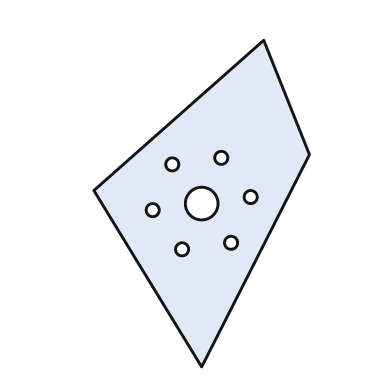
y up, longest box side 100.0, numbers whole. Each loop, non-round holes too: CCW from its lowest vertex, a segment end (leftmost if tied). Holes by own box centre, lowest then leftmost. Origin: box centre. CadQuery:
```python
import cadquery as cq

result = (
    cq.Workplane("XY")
    .moveTo(0.0, -50.0)
    .lineTo(33.0, 15.0)
    .lineTo(19.0, 50.0)
    .lineTo(-33.0, 4.0)
    .close()
    .moveTo(-6.0, -14.0)
    .circle(2.0)
    .moveTo(9.0, -12.0)
    .circle(2.0)
    .moveTo(-15.0, -2.0)
    .circle(2.0)
    .moveTo(0.0, 0.0)
    .circle(5.0)
    .moveTo(15.0, 2.0)
    .circle(2.0)
    .moveTo(-9.0, 12.0)
    .circle(2.0)
    .moveTo(6.0, 14.0)
    .circle(2.0)
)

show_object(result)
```